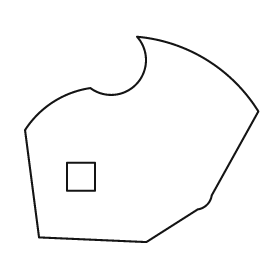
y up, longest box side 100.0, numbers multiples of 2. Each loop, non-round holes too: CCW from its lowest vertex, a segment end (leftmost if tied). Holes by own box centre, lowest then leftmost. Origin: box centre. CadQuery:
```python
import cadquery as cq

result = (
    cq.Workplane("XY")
    .moveTo(2.0, -44.0)
    .lineTo(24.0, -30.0)
    .threePointArc((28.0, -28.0), (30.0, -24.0))
    .lineTo(50.0, 12.0)
    .threePointArc((28.0, 34.0), (-2.0, 44.0))
    .threePointArc((-2.0, 24.0), (-22.0, 22.0))
    .threePointArc((-38.0, 16.0), (-50.0, 4.0))
    .lineTo(-44.0, -42.0)
    .close()
    .moveTo(-32.0, -22.0)
    .lineTo(-20.0, -22.0)
    .lineTo(-20.0, -10.0)
    .lineTo(-32.0, -10.0)
    .close()
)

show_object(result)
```